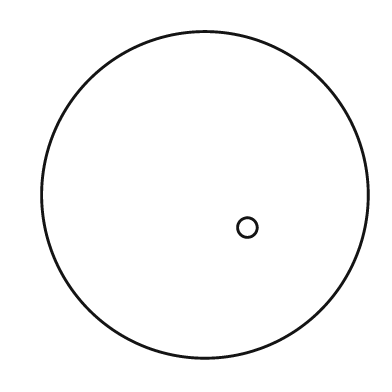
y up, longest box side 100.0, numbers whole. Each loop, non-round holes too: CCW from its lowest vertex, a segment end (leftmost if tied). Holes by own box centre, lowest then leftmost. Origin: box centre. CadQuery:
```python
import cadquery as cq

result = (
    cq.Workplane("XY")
    .moveTo(0.0, 0.0)
    .circle(50.0)
    .moveTo(13.0, -10.0)
    .circle(3.0)
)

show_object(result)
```